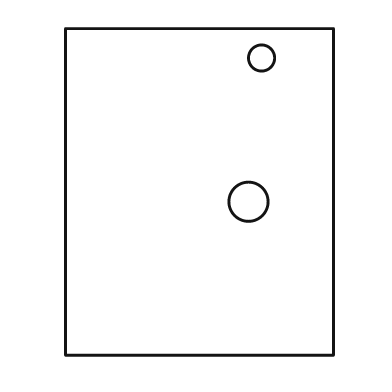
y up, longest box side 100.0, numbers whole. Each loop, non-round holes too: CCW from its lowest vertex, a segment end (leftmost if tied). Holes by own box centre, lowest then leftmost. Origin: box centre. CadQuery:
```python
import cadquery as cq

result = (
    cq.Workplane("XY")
    .moveTo(-41.0, -50.0)
    .lineTo(41.0, -50.0)
    .lineTo(41.0, 50.0)
    .lineTo(-41.0, 50.0)
    .close()
    .moveTo(15.0, -3.0)
    .circle(6.0)
    .moveTo(19.0, 41.0)
    .circle(4.0)
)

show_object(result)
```